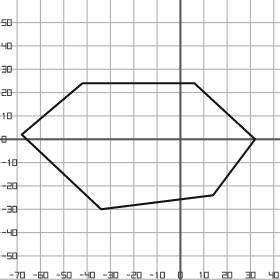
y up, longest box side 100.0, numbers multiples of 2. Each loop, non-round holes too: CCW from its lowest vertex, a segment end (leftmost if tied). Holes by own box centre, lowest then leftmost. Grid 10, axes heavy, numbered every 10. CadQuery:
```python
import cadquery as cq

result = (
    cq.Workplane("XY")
    .moveTo(-34.0, -30.0)
    .lineTo(14.0, -24.0)
    .lineTo(32.0, 0.0)
    .lineTo(6.0, 24.0)
    .lineTo(-42.0, 24.0)
    .lineTo(-68.0, 2.0)
    .close()
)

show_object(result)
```